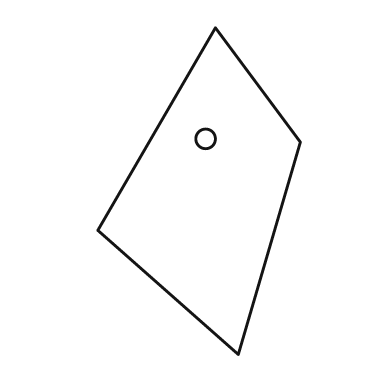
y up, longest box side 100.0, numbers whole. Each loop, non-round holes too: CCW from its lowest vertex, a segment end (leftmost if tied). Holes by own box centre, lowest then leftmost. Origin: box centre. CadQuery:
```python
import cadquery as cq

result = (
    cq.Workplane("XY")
    .moveTo(12.0, -50.0)
    .lineTo(31.0, 15.0)
    .lineTo(5.0, 50.0)
    .lineTo(-31.0, -12.0)
    .close()
    .moveTo(2.0, 16.0)
    .circle(3.0)
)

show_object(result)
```